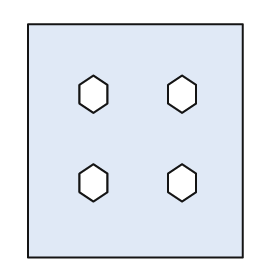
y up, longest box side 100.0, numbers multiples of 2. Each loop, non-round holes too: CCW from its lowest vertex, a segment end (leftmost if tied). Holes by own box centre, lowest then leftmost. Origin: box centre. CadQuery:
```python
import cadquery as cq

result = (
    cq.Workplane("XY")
    .moveTo(-46.0, -50.0)
    .lineTo(46.0, -50.0)
    .lineTo(46.0, 50.0)
    .lineTo(-46.0, 50.0)
    .close()
    .moveTo(-18.0, -26.0)
    .lineTo(-12.0, -22.0)
    .lineTo(-12.0, -14.0)
    .lineTo(-18.0, -10.0)
    .lineTo(-24.0, -14.0)
    .lineTo(-24.0, -22.0)
    .close()
    .moveTo(20.0, -26.0)
    .lineTo(26.0, -22.0)
    .lineTo(26.0, -14.0)
    .lineTo(20.0, -10.0)
    .lineTo(14.0, -14.0)
    .lineTo(14.0, -22.0)
    .close()
    .moveTo(-18.0, 12.0)
    .lineTo(-12.0, 16.0)
    .lineTo(-12.0, 24.0)
    .lineTo(-18.0, 28.0)
    .lineTo(-24.0, 24.0)
    .lineTo(-24.0, 16.0)
    .close()
    .moveTo(20.0, 12.0)
    .lineTo(26.0, 16.0)
    .lineTo(26.0, 24.0)
    .lineTo(20.0, 28.0)
    .lineTo(14.0, 24.0)
    .lineTo(14.0, 16.0)
    .close()
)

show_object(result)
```